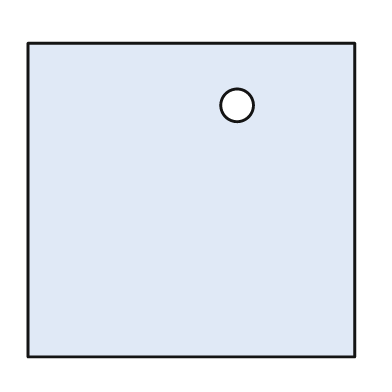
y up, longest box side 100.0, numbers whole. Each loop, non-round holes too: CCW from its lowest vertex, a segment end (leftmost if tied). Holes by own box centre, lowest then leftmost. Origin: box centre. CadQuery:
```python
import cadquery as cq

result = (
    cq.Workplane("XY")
    .moveTo(-50.0, -48.0)
    .lineTo(50.0, -48.0)
    .lineTo(50.0, 48.0)
    .lineTo(-50.0, 48.0)
    .close()
    .moveTo(14.0, 29.0)
    .circle(5.0)
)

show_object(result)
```